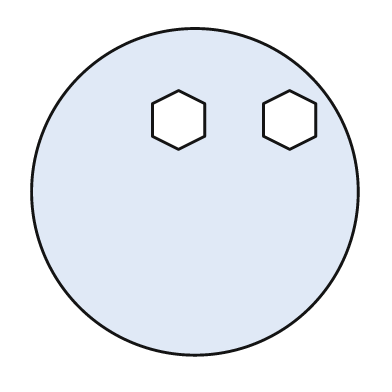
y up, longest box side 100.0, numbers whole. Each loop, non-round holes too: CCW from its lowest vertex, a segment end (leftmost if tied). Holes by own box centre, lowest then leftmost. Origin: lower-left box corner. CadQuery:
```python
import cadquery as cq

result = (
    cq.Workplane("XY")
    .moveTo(50.0, 50.0)
    .circle(50.0)
    .moveTo(45.0, 63.0)
    .lineTo(53.0, 67.0)
    .lineTo(53.0, 77.0)
    .lineTo(45.0, 81.0)
    .lineTo(37.0, 77.0)
    .lineTo(37.0, 67.0)
    .close()
    .moveTo(79.0, 63.0)
    .lineTo(87.0, 67.0)
    .lineTo(87.0, 77.0)
    .lineTo(79.0, 81.0)
    .lineTo(71.0, 77.0)
    .lineTo(71.0, 67.0)
    .close()
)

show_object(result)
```